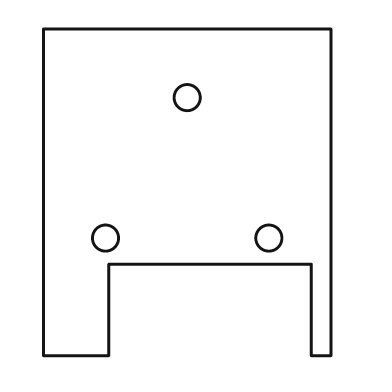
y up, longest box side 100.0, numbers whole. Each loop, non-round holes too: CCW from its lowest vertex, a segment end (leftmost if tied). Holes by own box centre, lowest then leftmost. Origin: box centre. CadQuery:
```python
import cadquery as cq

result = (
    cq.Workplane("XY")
    .moveTo(-44.0, -50.0)
    .lineTo(-24.0, -50.0)
    .lineTo(-24.0, -22.0)
    .lineTo(38.0, -22.0)
    .lineTo(38.0, -50.0)
    .lineTo(44.0, -50.0)
    .lineTo(44.0, 50.0)
    .lineTo(-44.0, 50.0)
    .close()
    .moveTo(-25.0, -14.0)
    .circle(4.0)
    .moveTo(25.0, -14.0)
    .circle(4.0)
    .moveTo(0.0, 29.0)
    .circle(4.0)
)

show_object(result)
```